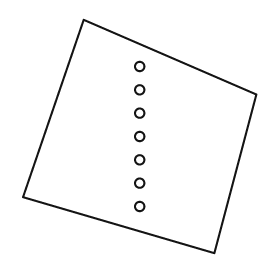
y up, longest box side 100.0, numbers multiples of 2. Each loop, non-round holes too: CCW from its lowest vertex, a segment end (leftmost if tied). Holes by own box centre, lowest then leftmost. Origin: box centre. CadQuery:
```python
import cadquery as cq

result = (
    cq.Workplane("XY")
    .moveTo(32.0, -50.0)
    .lineTo(50.0, 18.0)
    .lineTo(-24.0, 50.0)
    .lineTo(-50.0, -26.0)
    .close()
    .moveTo(0.0, -30.0)
    .circle(2.0)
    .moveTo(0.0, -20.0)
    .circle(2.0)
    .moveTo(0.0, -10.0)
    .circle(2.0)
    .moveTo(0.0, 0.0)
    .circle(2.0)
    .moveTo(0.0, 10.0)
    .circle(2.0)
    .moveTo(0.0, 20.0)
    .circle(2.0)
    .moveTo(0.0, 30.0)
    .circle(2.0)
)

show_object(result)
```